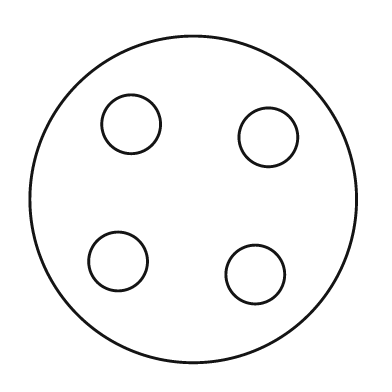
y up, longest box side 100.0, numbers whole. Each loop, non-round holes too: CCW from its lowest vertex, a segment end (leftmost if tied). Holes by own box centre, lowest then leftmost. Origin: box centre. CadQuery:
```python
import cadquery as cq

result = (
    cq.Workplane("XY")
    .moveTo(0.0, 0.0)
    .circle(50.0)
    .moveTo(19.0, -23.0)
    .circle(9.0)
    .moveTo(-23.0, -19.0)
    .circle(9.0)
    .moveTo(23.0, 19.0)
    .circle(9.0)
    .moveTo(-19.0, 23.0)
    .circle(9.0)
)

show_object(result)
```